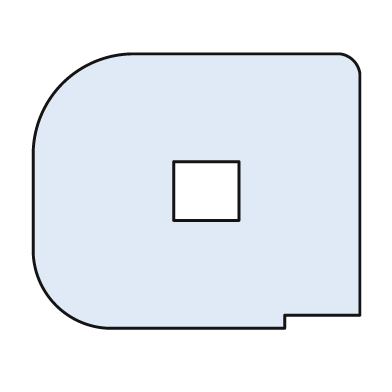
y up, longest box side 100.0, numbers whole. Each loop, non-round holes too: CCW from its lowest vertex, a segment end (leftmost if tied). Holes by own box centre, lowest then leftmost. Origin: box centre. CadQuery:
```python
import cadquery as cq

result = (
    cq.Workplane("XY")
    .moveTo(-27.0, -42.0)
    .lineTo(27.0, -42.0)
    .lineTo(27.0, -38.0)
    .lineTo(50.0, -38.0)
    .lineTo(50.0, 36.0)
    .threePointArc((48.0, 40.0), (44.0, 42.0))
    .lineTo(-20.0, 42.0)
    .threePointArc((-41.0, 33.0), (-50.0, 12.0))
    .lineTo(-50.0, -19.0)
    .threePointArc((-43.0, -35.0), (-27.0, -42.0))
    .close()
    .moveTo(-7.0, -9.0)
    .lineTo(13.0, -9.0)
    .lineTo(13.0, 9.0)
    .lineTo(-7.0, 9.0)
    .close()
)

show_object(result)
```